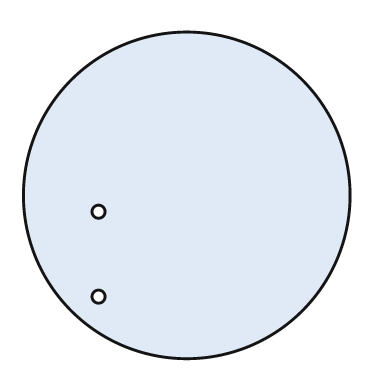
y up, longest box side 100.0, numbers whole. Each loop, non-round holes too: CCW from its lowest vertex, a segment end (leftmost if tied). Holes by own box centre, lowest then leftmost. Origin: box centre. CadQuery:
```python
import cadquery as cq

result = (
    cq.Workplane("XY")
    .moveTo(0.0, 0.0)
    .circle(50.0)
    .moveTo(-27.0, -31.0)
    .circle(2.0)
    .moveTo(-27.0, -5.0)
    .circle(2.0)
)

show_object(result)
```